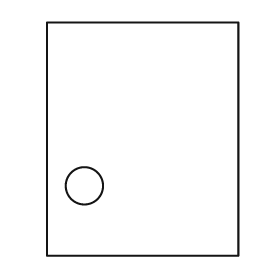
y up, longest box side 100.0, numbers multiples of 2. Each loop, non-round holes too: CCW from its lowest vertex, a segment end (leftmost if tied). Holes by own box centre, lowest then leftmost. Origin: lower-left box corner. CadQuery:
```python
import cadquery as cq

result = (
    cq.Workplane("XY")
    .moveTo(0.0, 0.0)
    .lineTo(82.0, 0.0)
    .lineTo(82.0, 100.0)
    .lineTo(0.0, 100.0)
    .close()
    .moveTo(16.0, 30.0)
    .circle(8.0)
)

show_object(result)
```